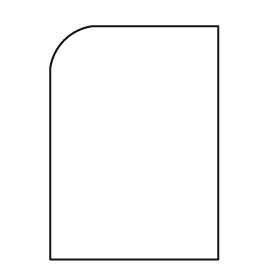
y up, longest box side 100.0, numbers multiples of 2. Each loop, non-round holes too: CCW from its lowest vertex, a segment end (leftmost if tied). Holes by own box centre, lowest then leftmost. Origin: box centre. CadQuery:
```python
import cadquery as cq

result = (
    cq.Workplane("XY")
    .moveTo(-36.0, -50.0)
    .lineTo(36.0, -50.0)
    .lineTo(36.0, 50.0)
    .lineTo(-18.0, 50.0)
    .threePointArc((-30.0, 44.0), (-36.0, 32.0))
    .close()
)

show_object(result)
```